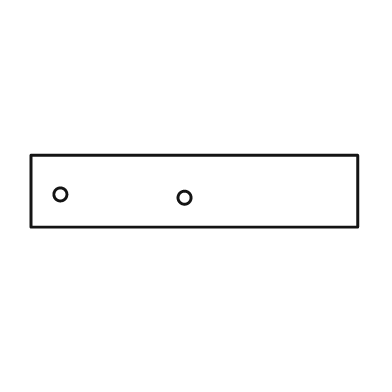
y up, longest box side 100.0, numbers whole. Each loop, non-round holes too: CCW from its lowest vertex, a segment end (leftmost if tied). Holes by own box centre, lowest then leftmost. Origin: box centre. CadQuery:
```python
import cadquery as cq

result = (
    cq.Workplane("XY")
    .moveTo(-50.0, -11.0)
    .lineTo(50.0, -11.0)
    .lineTo(50.0, 11.0)
    .lineTo(-50.0, 11.0)
    .close()
    .moveTo(-3.0, -2.0)
    .circle(2.0)
    .moveTo(-41.0, -1.0)
    .circle(2.0)
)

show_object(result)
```